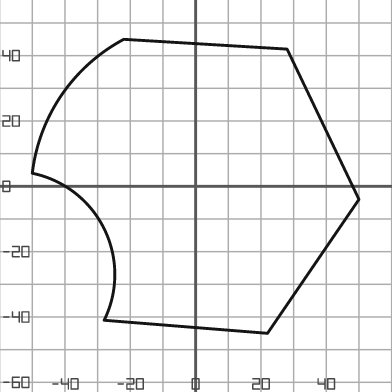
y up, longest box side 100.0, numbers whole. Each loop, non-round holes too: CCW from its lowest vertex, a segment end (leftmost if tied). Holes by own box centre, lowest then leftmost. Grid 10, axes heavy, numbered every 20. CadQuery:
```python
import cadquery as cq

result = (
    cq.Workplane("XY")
    .moveTo(22.0, -45.0)
    .lineTo(50.0, -4.0)
    .lineTo(28.0, 42.0)
    .lineTo(-22.0, 45.0)
    .threePointArc((-41.0, 28.0), (-50.0, 4.0))
    .threePointArc((-28.0, -13.0), (-28.0, -41.0))
    .close()
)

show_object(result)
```